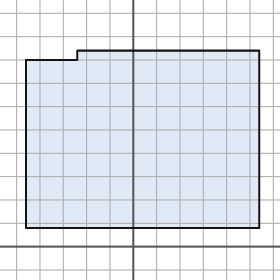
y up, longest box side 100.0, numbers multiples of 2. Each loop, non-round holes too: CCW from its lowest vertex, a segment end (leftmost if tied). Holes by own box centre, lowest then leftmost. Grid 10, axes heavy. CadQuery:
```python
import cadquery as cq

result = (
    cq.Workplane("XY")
    .moveTo(-46.0, 8.0)
    .lineTo(54.0, 8.0)
    .lineTo(54.0, 84.0)
    .lineTo(-24.0, 84.0)
    .lineTo(-24.0, 80.0)
    .lineTo(-46.0, 80.0)
    .close()
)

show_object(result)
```